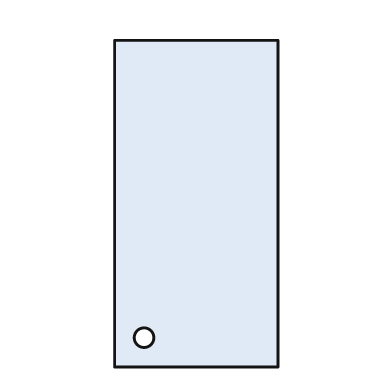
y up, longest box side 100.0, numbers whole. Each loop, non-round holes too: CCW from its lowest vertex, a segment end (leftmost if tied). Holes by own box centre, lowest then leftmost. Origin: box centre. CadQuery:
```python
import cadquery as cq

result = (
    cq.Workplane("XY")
    .moveTo(-25.0, -50.0)
    .lineTo(25.0, -50.0)
    .lineTo(25.0, 50.0)
    .lineTo(-25.0, 50.0)
    .close()
    .moveTo(-16.0, -41.0)
    .circle(3.0)
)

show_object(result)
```